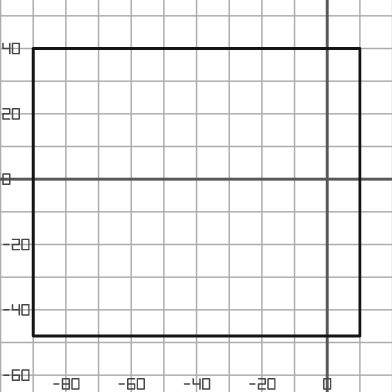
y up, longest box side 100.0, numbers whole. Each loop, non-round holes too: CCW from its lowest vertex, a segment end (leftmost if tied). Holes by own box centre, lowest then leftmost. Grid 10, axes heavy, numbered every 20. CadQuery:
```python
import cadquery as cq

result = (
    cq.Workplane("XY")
    .moveTo(-90.0, -48.0)
    .lineTo(10.0, -48.0)
    .lineTo(10.0, 40.0)
    .lineTo(-90.0, 40.0)
    .close()
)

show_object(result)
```